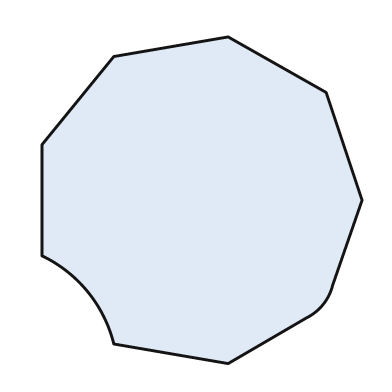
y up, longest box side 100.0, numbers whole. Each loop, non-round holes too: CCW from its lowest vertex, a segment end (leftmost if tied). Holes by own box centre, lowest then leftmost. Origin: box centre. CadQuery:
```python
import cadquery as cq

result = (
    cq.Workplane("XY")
    .moveTo(8.0, -50.0)
    .lineTo(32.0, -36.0)
    .threePointArc((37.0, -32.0), (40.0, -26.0))
    .lineTo(49.0, 0.0)
    .lineTo(38.0, 33.0)
    .lineTo(8.0, 50.0)
    .lineTo(-27.0, 44.0)
    .lineTo(-49.0, 17.0)
    .lineTo(-49.0, -17.0)
    .threePointArc((-35.0, -28.0), (-27.0, -44.0))
    .close()
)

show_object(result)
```